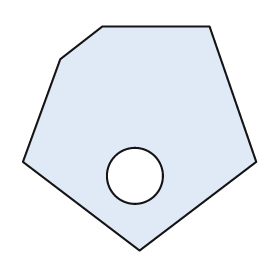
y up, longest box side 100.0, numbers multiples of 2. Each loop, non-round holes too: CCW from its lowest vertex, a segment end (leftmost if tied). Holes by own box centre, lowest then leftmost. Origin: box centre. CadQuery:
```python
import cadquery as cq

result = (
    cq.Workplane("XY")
    .moveTo(0.0, -48.0)
    .lineTo(50.0, -10.0)
    .lineTo(30.0, 48.0)
    .lineTo(-16.0, 48.0)
    .lineTo(-34.0, 34.0)
    .lineTo(-50.0, -10.0)
    .close()
    .moveTo(-2.0, -16.0)
    .circle(12.0)
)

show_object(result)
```